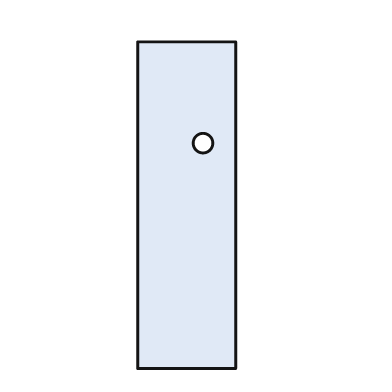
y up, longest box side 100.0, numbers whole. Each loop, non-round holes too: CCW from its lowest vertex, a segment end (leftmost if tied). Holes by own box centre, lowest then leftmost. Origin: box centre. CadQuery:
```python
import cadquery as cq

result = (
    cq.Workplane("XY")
    .moveTo(-15.0, -50.0)
    .lineTo(15.0, -50.0)
    .lineTo(15.0, 50.0)
    .lineTo(-15.0, 50.0)
    .close()
    .moveTo(5.0, 19.0)
    .circle(3.0)
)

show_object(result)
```